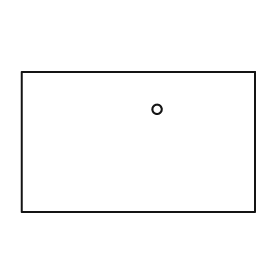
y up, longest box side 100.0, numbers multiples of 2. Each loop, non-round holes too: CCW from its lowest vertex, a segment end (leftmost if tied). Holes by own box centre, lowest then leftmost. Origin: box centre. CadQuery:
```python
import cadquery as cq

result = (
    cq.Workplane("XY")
    .moveTo(-50.0, -30.0)
    .lineTo(50.0, -30.0)
    .lineTo(50.0, 30.0)
    .lineTo(-50.0, 30.0)
    .close()
    .moveTo(8.0, 14.0)
    .circle(2.0)
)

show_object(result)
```